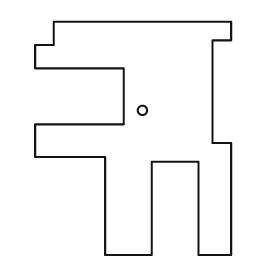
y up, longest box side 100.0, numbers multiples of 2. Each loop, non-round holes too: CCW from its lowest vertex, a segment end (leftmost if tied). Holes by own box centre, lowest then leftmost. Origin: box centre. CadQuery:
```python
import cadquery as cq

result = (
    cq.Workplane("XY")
    .moveTo(-12.0, -50.0)
    .lineTo(8.0, -50.0)
    .lineTo(8.0, -10.0)
    .lineTo(28.0, -10.0)
    .lineTo(28.0, -50.0)
    .lineTo(42.0, -50.0)
    .lineTo(42.0, -2.0)
    .lineTo(34.0, -2.0)
    .lineTo(34.0, 42.0)
    .lineTo(42.0, 42.0)
    .lineTo(42.0, 50.0)
    .lineTo(-34.0, 50.0)
    .lineTo(-34.0, 40.0)
    .lineTo(-42.0, 40.0)
    .lineTo(-42.0, 30.0)
    .lineTo(-4.0, 30.0)
    .lineTo(-4.0, 6.0)
    .lineTo(-42.0, 6.0)
    .lineTo(-42.0, -8.0)
    .lineTo(-12.0, -8.0)
    .close()
    .moveTo(4.0, 12.0)
    .circle(2.0)
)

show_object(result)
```